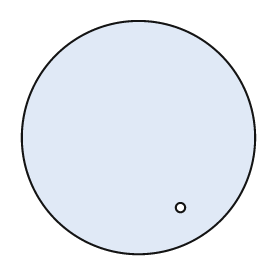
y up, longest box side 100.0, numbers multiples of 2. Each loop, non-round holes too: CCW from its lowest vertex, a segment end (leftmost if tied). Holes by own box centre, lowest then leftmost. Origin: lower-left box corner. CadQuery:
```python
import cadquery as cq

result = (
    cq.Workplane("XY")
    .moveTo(50.0, 50.0)
    .circle(50.0)
    .moveTo(68.0, 20.0)
    .circle(2.0)
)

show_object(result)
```